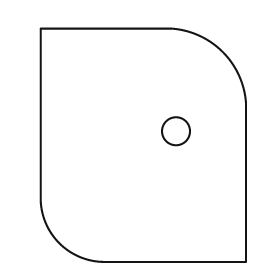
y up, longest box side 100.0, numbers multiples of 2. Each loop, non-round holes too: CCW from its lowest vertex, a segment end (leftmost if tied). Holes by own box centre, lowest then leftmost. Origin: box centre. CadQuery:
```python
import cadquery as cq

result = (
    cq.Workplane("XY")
    .moveTo(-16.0, -50.0)
    .lineTo(44.0, -50.0)
    .lineTo(44.0, 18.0)
    .threePointArc((34.0, 40.0), (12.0, 50.0))
    .lineTo(-44.0, 50.0)
    .lineTo(-44.0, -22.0)
    .threePointArc((-36.0, -42.0), (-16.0, -50.0))
    .close()
    .moveTo(14.0, 6.0)
    .circle(6.0)
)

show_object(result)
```